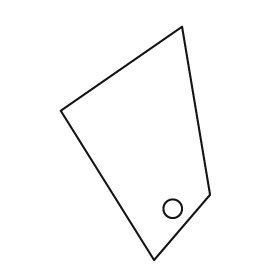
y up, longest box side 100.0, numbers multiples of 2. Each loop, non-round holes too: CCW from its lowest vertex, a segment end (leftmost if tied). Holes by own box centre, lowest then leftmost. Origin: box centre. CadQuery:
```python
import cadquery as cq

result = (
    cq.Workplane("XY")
    .moveTo(8.0, -50.0)
    .lineTo(32.0, -22.0)
    .lineTo(20.0, 50.0)
    .lineTo(-32.0, 14.0)
    .close()
    .moveTo(16.0, -28.0)
    .circle(4.0)
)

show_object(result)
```